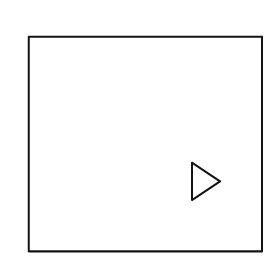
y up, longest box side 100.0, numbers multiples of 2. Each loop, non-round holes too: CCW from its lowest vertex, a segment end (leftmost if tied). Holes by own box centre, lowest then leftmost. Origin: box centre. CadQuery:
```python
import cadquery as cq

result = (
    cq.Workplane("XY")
    .moveTo(-50.0, -46.0)
    .lineTo(50.0, -46.0)
    .lineTo(50.0, 46.0)
    .lineTo(-50.0, 46.0)
    .close()
    .moveTo(20.0, -24.0)
    .lineTo(32.0, -16.0)
    .lineTo(20.0, -8.0)
    .close()
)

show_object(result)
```